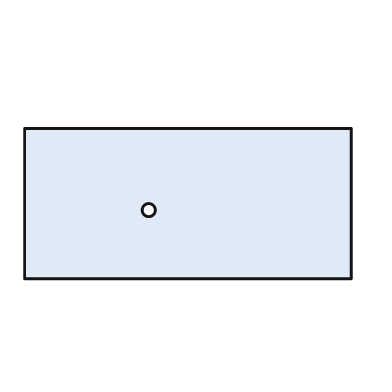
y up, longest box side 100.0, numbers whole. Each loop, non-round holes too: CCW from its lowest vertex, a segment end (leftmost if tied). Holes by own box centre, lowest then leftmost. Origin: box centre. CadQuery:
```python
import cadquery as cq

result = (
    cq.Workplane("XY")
    .moveTo(-50.0, -23.0)
    .lineTo(50.0, -23.0)
    .lineTo(50.0, 23.0)
    .lineTo(-50.0, 23.0)
    .close()
    .moveTo(-12.0, -2.0)
    .circle(2.0)
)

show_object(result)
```